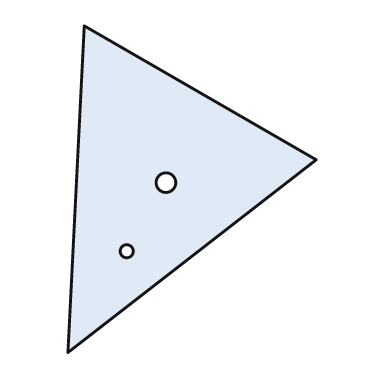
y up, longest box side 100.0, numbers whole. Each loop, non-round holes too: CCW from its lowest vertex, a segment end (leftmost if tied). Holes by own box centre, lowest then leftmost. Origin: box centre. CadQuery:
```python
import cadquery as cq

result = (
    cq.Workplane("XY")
    .moveTo(-38.0, -50.0)
    .lineTo(38.0, 9.0)
    .lineTo(-33.0, 50.0)
    .close()
    .moveTo(-20.0, -19.0)
    .circle(2.0)
    .moveTo(-8.0, 2.0)
    .circle(3.0)
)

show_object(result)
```